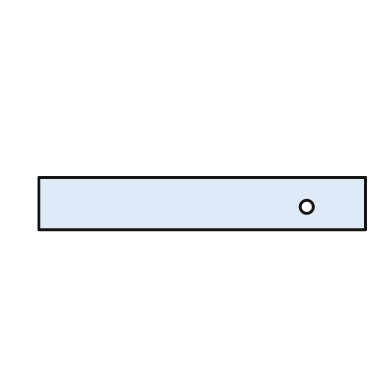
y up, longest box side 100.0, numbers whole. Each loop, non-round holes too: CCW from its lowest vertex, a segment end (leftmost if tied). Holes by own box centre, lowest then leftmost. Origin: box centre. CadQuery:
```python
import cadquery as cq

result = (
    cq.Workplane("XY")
    .moveTo(-50.0, -8.0)
    .lineTo(50.0, -8.0)
    .lineTo(50.0, 8.0)
    .lineTo(-50.0, 8.0)
    .close()
    .moveTo(32.0, -1.0)
    .circle(2.0)
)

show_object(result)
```